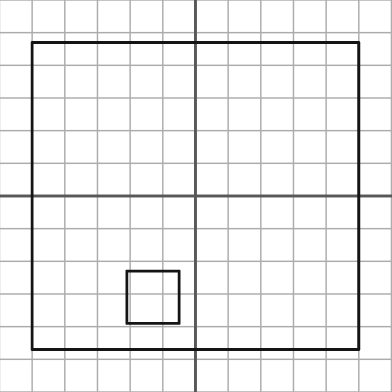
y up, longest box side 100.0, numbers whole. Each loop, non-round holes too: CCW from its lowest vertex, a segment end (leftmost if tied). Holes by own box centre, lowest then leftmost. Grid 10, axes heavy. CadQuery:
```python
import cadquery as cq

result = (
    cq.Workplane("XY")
    .moveTo(-50.0, -47.0)
    .lineTo(50.0, -47.0)
    .lineTo(50.0, 47.0)
    .lineTo(-50.0, 47.0)
    .close()
    .moveTo(-21.0, -39.0)
    .lineTo(-5.0, -39.0)
    .lineTo(-5.0, -23.0)
    .lineTo(-21.0, -23.0)
    .close()
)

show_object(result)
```